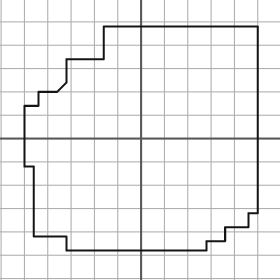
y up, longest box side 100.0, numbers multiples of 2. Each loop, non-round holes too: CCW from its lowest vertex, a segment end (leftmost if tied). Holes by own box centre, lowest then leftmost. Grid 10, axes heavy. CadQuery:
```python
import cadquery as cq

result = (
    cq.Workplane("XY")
    .moveTo(-32.0, -48.0)
    .lineTo(28.0, -48.0)
    .lineTo(28.0, -44.0)
    .lineTo(36.0, -44.0)
    .lineTo(36.0, -38.0)
    .lineTo(46.0, -38.0)
    .lineTo(46.0, -32.0)
    .lineTo(50.0, -32.0)
    .lineTo(50.0, 48.0)
    .lineTo(-16.0, 48.0)
    .lineTo(-16.0, 34.0)
    .lineTo(-32.0, 34.0)
    .lineTo(-32.0, 24.0)
    .lineTo(-36.0, 20.0)
    .lineTo(-44.0, 20.0)
    .lineTo(-44.0, 14.0)
    .lineTo(-50.0, 14.0)
    .lineTo(-50.0, -12.0)
    .lineTo(-46.0, -12.0)
    .lineTo(-46.0, -42.0)
    .lineTo(-32.0, -42.0)
    .close()
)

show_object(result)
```